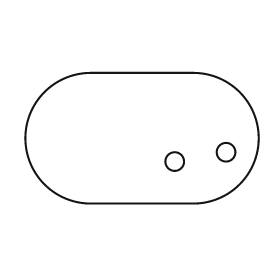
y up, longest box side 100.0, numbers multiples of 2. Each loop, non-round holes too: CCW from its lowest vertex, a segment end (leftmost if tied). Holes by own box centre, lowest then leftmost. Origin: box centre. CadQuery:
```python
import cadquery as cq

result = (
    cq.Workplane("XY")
    .moveTo(-22.0, -28.0)
    .lineTo(22.0, -28.0)
    .threePointArc((50.0, 0.0), (22.0, 28.0))
    .lineTo(-22.0, 28.0)
    .threePointArc((-50.0, 0.0), (-22.0, -28.0))
    .close()
    .moveTo(14.0, -10.0)
    .circle(4.0)
    .moveTo(36.0, -6.0)
    .circle(4.0)
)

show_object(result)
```